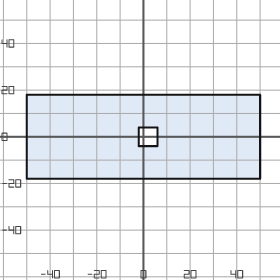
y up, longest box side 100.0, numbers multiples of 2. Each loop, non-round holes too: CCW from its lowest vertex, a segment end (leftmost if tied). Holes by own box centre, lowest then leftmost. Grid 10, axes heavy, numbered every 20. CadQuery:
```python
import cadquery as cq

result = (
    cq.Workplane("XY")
    .moveTo(-50.0, -18.0)
    .lineTo(50.0, -18.0)
    .lineTo(50.0, 18.0)
    .lineTo(-50.0, 18.0)
    .close()
    .moveTo(-2.0, -4.0)
    .lineTo(6.0, -4.0)
    .lineTo(6.0, 4.0)
    .lineTo(-2.0, 4.0)
    .close()
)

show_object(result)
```